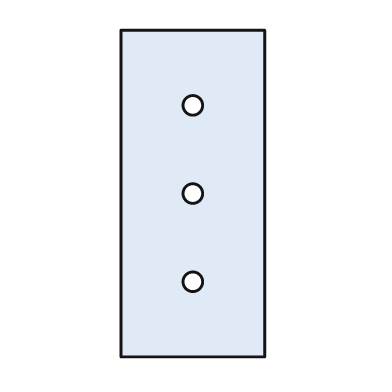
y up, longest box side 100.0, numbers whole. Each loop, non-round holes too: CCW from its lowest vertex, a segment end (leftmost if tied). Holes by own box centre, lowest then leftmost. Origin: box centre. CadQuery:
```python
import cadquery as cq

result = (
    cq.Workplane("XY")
    .moveTo(-22.0, -50.0)
    .lineTo(22.0, -50.0)
    .lineTo(22.0, 50.0)
    .lineTo(-22.0, 50.0)
    .close()
    .moveTo(0.0, -27.0)
    .circle(3.0)
    .moveTo(0.0, 0.0)
    .circle(3.0)
    .moveTo(0.0, 27.0)
    .circle(3.0)
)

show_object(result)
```